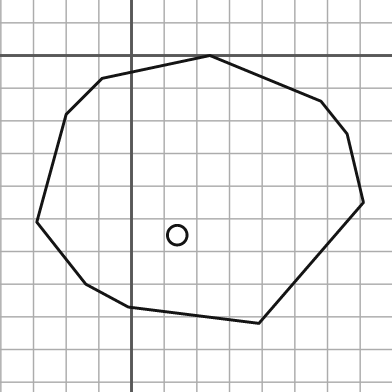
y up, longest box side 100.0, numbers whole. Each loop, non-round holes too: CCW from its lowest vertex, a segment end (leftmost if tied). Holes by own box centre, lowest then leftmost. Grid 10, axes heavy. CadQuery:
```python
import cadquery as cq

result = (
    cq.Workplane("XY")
    .moveTo(39.0, -82.0)
    .lineTo(71.0, -45.0)
    .lineTo(66.0, -24.0)
    .lineTo(58.0, -14.0)
    .lineTo(24.0, 0.0)
    .lineTo(-9.0, -7.0)
    .lineTo(-20.0, -18.0)
    .lineTo(-29.0, -51.0)
    .lineTo(-14.0, -70.0)
    .lineTo(-1.0, -77.0)
    .close()
    .moveTo(14.0, -55.0)
    .circle(3.0)
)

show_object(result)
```